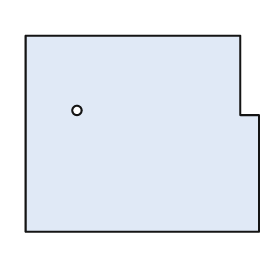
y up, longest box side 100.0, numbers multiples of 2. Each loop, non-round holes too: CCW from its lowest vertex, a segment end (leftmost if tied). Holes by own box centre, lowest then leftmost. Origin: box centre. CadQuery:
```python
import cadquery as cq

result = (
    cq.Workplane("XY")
    .moveTo(-50.0, -42.0)
    .lineTo(50.0, -42.0)
    .lineTo(50.0, 8.0)
    .lineTo(42.0, 8.0)
    .lineTo(42.0, 42.0)
    .lineTo(-50.0, 42.0)
    .close()
    .moveTo(-28.0, 10.0)
    .circle(2.0)
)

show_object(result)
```